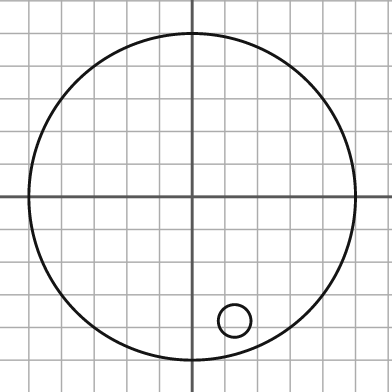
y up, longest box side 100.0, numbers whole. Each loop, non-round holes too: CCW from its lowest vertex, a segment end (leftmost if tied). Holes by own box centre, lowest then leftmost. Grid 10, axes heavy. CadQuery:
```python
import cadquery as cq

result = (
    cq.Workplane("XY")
    .moveTo(0.0, 0.0)
    .circle(50.0)
    .moveTo(13.0, -38.0)
    .circle(5.0)
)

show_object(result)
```